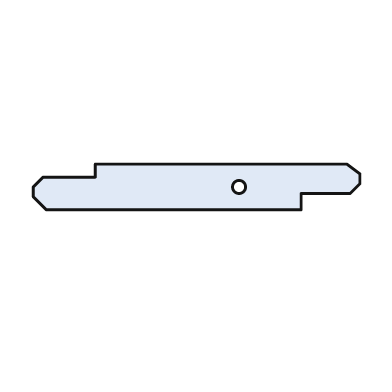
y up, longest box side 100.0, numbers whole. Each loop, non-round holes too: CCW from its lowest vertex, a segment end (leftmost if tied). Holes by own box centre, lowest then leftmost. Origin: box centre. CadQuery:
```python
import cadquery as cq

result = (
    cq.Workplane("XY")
    .moveTo(-46.0, -7.0)
    .lineTo(32.0, -7.0)
    .lineTo(32.0, -2.0)
    .lineTo(47.0, -2.0)
    .lineTo(50.0, 1.0)
    .lineTo(50.0, 4.0)
    .lineTo(46.0, 7.0)
    .lineTo(-31.0, 7.0)
    .lineTo(-31.0, 3.0)
    .lineTo(-47.0, 3.0)
    .lineTo(-50.0, 0.0)
    .lineTo(-50.0, -3.0)
    .close()
    .moveTo(13.0, 0.0)
    .circle(2.0)
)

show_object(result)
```